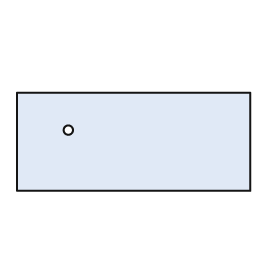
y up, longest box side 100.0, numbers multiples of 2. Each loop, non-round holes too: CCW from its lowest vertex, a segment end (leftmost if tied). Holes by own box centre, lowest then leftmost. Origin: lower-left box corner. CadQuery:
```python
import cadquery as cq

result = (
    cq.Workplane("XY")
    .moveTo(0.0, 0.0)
    .lineTo(100.0, 0.0)
    .lineTo(100.0, 42.0)
    .lineTo(0.0, 42.0)
    .close()
    .moveTo(22.0, 26.0)
    .circle(2.0)
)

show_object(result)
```